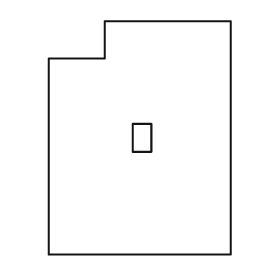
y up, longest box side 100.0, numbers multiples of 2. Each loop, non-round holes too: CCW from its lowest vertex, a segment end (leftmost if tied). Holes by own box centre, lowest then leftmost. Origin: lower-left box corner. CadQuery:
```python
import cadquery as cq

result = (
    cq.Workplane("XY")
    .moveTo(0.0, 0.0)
    .lineTo(78.0, 0.0)
    .lineTo(78.0, 100.0)
    .lineTo(24.0, 100.0)
    .lineTo(24.0, 84.0)
    .lineTo(0.0, 84.0)
    .close()
    .moveTo(36.0, 44.0)
    .lineTo(44.0, 44.0)
    .lineTo(44.0, 56.0)
    .lineTo(36.0, 56.0)
    .close()
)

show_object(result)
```